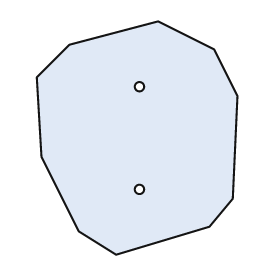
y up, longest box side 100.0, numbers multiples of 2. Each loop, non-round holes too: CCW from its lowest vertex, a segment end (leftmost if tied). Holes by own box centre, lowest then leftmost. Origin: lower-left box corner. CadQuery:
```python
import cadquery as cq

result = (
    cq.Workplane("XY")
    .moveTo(34.0, 0.0)
    .lineTo(74.0, 12.0)
    .lineTo(84.0, 24.0)
    .lineTo(86.0, 68.0)
    .lineTo(76.0, 88.0)
    .lineTo(52.0, 100.0)
    .lineTo(14.0, 90.0)
    .lineTo(0.0, 76.0)
    .lineTo(2.0, 42.0)
    .lineTo(18.0, 10.0)
    .close()
    .moveTo(44.0, 28.0)
    .circle(2.0)
    .moveTo(44.0, 72.0)
    .circle(2.0)
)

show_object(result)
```